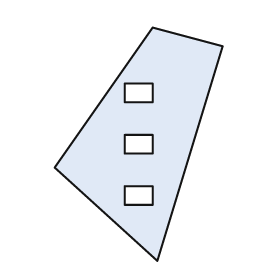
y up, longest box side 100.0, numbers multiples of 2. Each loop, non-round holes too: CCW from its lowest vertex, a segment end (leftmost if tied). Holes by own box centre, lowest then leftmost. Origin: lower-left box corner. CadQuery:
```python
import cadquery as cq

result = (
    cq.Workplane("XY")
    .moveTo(44.0, 0.0)
    .lineTo(72.0, 92.0)
    .lineTo(42.0, 100.0)
    .lineTo(0.0, 40.0)
    .close()
    .moveTo(30.0, 24.0)
    .lineTo(42.0, 24.0)
    .lineTo(42.0, 32.0)
    .lineTo(30.0, 32.0)
    .close()
    .moveTo(30.0, 46.0)
    .lineTo(42.0, 46.0)
    .lineTo(42.0, 54.0)
    .lineTo(30.0, 54.0)
    .close()
    .moveTo(30.0, 68.0)
    .lineTo(42.0, 68.0)
    .lineTo(42.0, 76.0)
    .lineTo(30.0, 76.0)
    .close()
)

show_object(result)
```